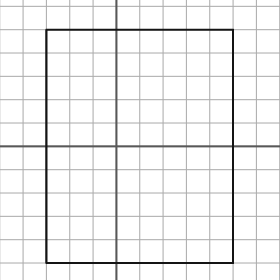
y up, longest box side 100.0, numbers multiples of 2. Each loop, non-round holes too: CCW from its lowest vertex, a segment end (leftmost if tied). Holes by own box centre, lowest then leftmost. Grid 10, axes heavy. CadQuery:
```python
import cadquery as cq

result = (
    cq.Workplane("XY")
    .moveTo(-30.0, -50.0)
    .lineTo(50.0, -50.0)
    .lineTo(50.0, 50.0)
    .lineTo(-30.0, 50.0)
    .close()
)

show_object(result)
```